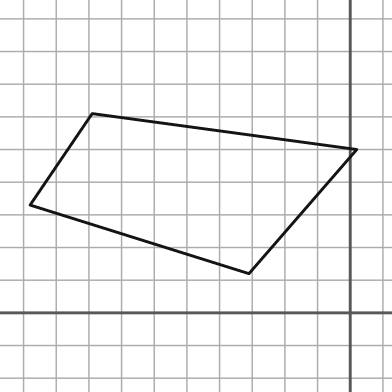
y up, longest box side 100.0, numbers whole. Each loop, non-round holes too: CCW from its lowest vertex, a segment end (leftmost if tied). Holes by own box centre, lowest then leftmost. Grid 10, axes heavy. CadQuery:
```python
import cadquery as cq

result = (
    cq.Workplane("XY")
    .moveTo(-31.0, 12.0)
    .lineTo(2.0, 50.0)
    .lineTo(-79.0, 61.0)
    .lineTo(-98.0, 33.0)
    .close()
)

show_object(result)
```